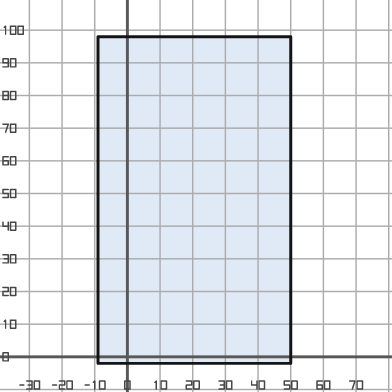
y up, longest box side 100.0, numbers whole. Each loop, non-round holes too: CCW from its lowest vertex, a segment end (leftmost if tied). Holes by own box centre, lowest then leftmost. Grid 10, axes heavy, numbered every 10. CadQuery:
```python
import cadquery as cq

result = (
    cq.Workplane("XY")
    .moveTo(-9.0, -2.0)
    .lineTo(50.0, -2.0)
    .lineTo(50.0, 98.0)
    .lineTo(-9.0, 98.0)
    .close()
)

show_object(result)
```